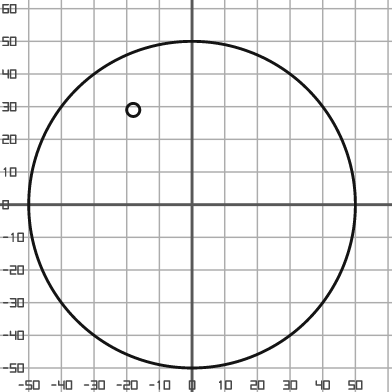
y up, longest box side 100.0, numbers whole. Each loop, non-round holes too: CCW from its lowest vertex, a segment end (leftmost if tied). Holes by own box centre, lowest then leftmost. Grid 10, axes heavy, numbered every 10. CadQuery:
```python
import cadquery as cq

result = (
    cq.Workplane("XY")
    .moveTo(0.0, 0.0)
    .circle(50.0)
    .moveTo(-18.0, 29.0)
    .circle(2.0)
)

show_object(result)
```